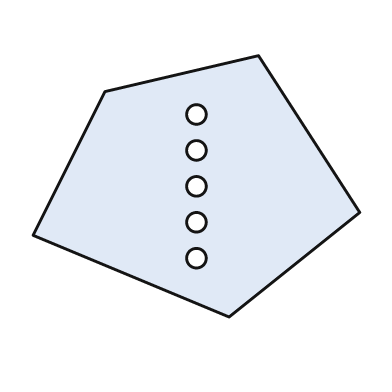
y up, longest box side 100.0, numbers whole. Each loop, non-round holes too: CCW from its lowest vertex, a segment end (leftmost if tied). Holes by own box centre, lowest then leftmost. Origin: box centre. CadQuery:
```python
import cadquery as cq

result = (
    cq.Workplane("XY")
    .moveTo(10.0, -40.0)
    .lineTo(50.0, -8.0)
    .lineTo(19.0, 40.0)
    .lineTo(-28.0, 29.0)
    .lineTo(-50.0, -15.0)
    .close()
    .moveTo(0.0, -22.0)
    .circle(3.0)
    .moveTo(0.0, -11.0)
    .circle(3.0)
    .moveTo(0.0, 0.0)
    .circle(3.0)
    .moveTo(0.0, 11.0)
    .circle(3.0)
    .moveTo(0.0, 22.0)
    .circle(3.0)
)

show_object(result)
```